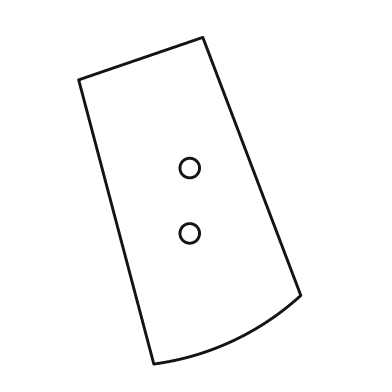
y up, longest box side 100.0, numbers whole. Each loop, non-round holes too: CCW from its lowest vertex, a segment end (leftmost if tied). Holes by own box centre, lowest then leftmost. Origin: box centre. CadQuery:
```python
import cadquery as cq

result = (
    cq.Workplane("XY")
    .moveTo(-11.0, -50.0)
    .threePointArc((13.0, -43.0), (34.0, -29.0))
    .lineTo(4.0, 50.0)
    .lineTo(-34.0, 37.0)
    .close()
    .moveTo(0.0, -10.0)
    .circle(3.0)
    .moveTo(0.0, 10.0)
    .circle(3.0)
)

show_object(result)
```